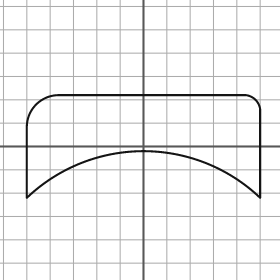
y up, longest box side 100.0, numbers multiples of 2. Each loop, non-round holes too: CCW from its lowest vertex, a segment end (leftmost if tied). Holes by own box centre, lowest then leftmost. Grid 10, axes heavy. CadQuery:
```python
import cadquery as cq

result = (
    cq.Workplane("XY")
    .moveTo(-50.0, -22.0)
    .threePointArc((0.0, -2.0), (50.0, -22.0))
    .lineTo(50.0, 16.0)
    .threePointArc((48.0, 20.0), (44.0, 22.0))
    .lineTo(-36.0, 22.0)
    .threePointArc((-46.0, 18.0), (-50.0, 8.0))
    .close()
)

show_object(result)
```